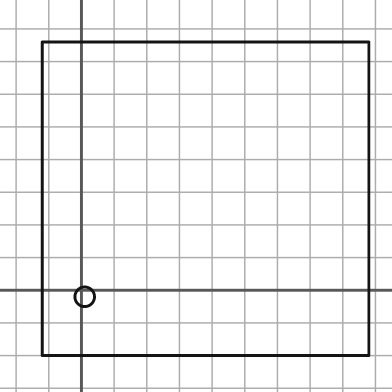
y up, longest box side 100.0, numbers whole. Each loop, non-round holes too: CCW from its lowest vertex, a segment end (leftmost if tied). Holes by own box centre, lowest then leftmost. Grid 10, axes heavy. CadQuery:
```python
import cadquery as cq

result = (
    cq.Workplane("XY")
    .moveTo(-12.0, -20.0)
    .lineTo(88.0, -20.0)
    .lineTo(88.0, 76.0)
    .lineTo(-12.0, 76.0)
    .close()
    .moveTo(1.0, -2.0)
    .circle(3.0)
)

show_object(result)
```